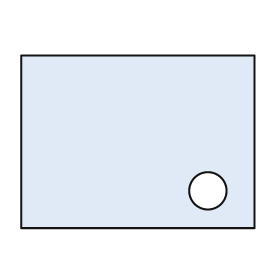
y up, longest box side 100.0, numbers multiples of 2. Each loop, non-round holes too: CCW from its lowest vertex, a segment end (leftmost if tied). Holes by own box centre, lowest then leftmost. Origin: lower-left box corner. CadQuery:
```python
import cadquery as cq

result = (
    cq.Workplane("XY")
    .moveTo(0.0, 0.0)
    .lineTo(100.0, 0.0)
    .lineTo(100.0, 74.0)
    .lineTo(0.0, 74.0)
    .close()
    .moveTo(80.0, 16.0)
    .circle(8.0)
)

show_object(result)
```